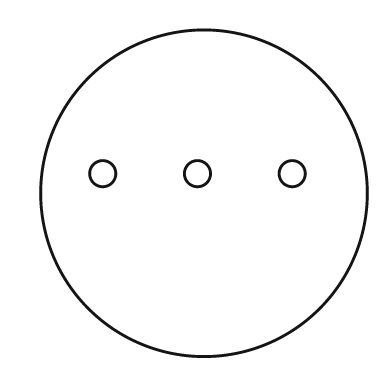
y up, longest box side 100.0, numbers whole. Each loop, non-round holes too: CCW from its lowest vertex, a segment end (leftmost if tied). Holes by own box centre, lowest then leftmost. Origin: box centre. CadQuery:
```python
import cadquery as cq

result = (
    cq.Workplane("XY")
    .moveTo(0.0, 0.0)
    .circle(50.0)
    .moveTo(-31.0, 6.0)
    .circle(4.0)
    .moveTo(-2.0, 6.0)
    .circle(4.0)
    .moveTo(27.0, 6.0)
    .circle(4.0)
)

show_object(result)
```